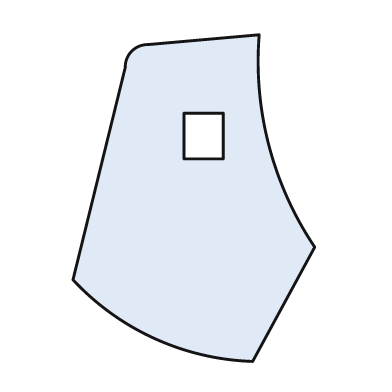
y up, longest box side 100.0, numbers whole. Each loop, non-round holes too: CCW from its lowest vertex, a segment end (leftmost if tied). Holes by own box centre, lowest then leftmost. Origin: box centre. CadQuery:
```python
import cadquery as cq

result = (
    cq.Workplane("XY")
    .moveTo(18.0, -50.0)
    .lineTo(37.0, -15.0)
    .threePointArc((23.0, 16.0), (20.0, 50.0))
    .lineTo(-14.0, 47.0)
    .threePointArc((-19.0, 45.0), (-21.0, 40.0))
    .lineTo(-37.0, -25.0)
    .threePointArc((-12.0, -43.0), (18.0, -50.0))
    .close()
    .moveTo(-3.0, 12.0)
    .lineTo(9.0, 12.0)
    .lineTo(9.0, 26.0)
    .lineTo(-3.0, 26.0)
    .close()
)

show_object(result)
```